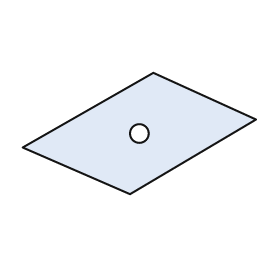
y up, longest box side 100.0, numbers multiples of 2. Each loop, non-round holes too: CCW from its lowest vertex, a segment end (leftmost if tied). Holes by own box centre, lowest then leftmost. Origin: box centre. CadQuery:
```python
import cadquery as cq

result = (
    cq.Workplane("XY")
    .moveTo(-4.0, -26.0)
    .lineTo(50.0, 6.0)
    .lineTo(6.0, 26.0)
    .lineTo(-50.0, -6.0)
    .close()
    .moveTo(0.0, 0.0)
    .circle(4.0)
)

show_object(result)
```